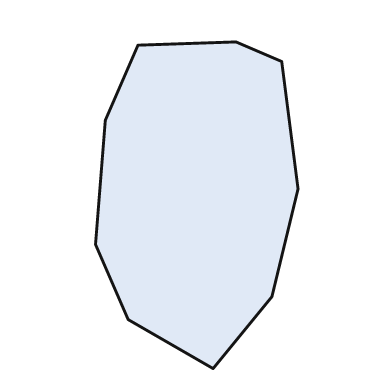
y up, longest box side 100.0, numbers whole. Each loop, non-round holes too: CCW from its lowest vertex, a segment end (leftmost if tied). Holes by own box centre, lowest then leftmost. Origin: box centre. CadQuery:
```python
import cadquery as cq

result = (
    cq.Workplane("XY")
    .moveTo(5.0, -50.0)
    .lineTo(23.0, -28.0)
    .lineTo(31.0, 5.0)
    .lineTo(26.0, 44.0)
    .lineTo(12.0, 50.0)
    .lineTo(-18.0, 49.0)
    .lineTo(-28.0, 26.0)
    .lineTo(-31.0, -12.0)
    .lineTo(-21.0, -35.0)
    .close()
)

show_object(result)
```